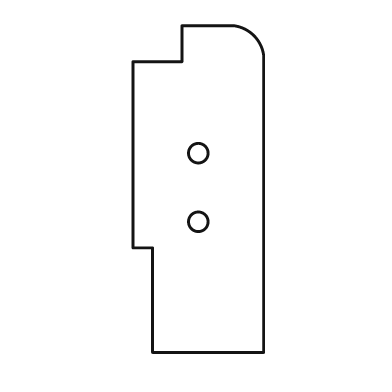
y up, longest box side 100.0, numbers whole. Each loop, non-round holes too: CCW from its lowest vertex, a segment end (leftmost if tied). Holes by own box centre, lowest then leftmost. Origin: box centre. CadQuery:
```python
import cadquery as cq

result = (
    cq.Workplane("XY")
    .moveTo(-14.0, -50.0)
    .lineTo(20.0, -50.0)
    .lineTo(20.0, 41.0)
    .threePointArc((17.0, 47.0), (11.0, 50.0))
    .lineTo(-5.0, 50.0)
    .lineTo(-5.0, 39.0)
    .lineTo(-20.0, 39.0)
    .lineTo(-20.0, -18.0)
    .lineTo(-14.0, -18.0)
    .close()
    .moveTo(0.0, -10.0)
    .circle(3.0)
    .moveTo(0.0, 11.0)
    .circle(3.0)
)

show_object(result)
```